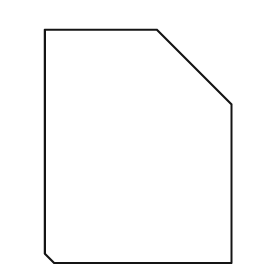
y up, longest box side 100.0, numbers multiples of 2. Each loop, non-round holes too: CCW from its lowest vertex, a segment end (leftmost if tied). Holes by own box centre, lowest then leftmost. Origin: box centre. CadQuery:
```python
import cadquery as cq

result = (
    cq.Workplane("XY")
    .moveTo(-36.0, -50.0)
    .lineTo(40.0, -50.0)
    .lineTo(40.0, 18.0)
    .lineTo(8.0, 50.0)
    .lineTo(-40.0, 50.0)
    .lineTo(-40.0, -46.0)
    .close()
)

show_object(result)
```